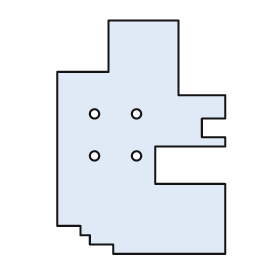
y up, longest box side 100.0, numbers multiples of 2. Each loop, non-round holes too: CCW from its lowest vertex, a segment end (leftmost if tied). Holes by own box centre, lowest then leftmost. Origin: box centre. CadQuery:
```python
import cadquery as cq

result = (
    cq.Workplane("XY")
    .moveTo(-12.0, -50.0)
    .lineTo(36.0, -50.0)
    .lineTo(36.0, -20.0)
    .lineTo(6.0, -20.0)
    .lineTo(6.0, -4.0)
    .lineTo(36.0, -4.0)
    .lineTo(36.0, 0.0)
    .lineTo(26.0, 0.0)
    .lineTo(26.0, 8.0)
    .lineTo(36.0, 8.0)
    .lineTo(36.0, 18.0)
    .lineTo(16.0, 18.0)
    .lineTo(16.0, 50.0)
    .lineTo(-14.0, 50.0)
    .lineTo(-14.0, 28.0)
    .lineTo(-36.0, 28.0)
    .lineTo(-36.0, -38.0)
    .lineTo(-26.0, -38.0)
    .lineTo(-26.0, -42.0)
    .lineTo(-22.0, -42.0)
    .lineTo(-22.0, -46.0)
    .lineTo(-12.0, -46.0)
    .close()
    .moveTo(-20.0, -8.0)
    .circle(2.0)
    .moveTo(-2.0, -8.0)
    .circle(2.0)
    .moveTo(-20.0, 10.0)
    .circle(2.0)
    .moveTo(-2.0, 10.0)
    .circle(2.0)
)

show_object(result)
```